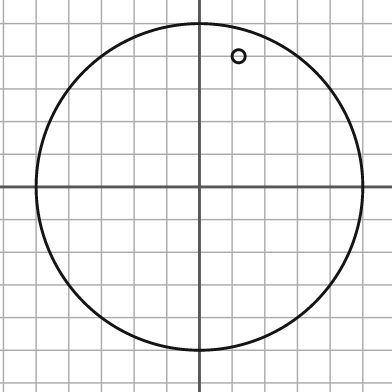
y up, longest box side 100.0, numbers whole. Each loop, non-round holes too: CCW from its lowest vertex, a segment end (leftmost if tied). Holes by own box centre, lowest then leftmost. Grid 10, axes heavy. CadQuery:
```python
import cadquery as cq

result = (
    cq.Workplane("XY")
    .moveTo(0.0, 0.0)
    .circle(50.0)
    .moveTo(12.0, 40.0)
    .circle(2.0)
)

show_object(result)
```